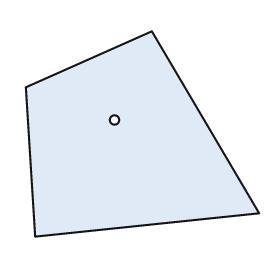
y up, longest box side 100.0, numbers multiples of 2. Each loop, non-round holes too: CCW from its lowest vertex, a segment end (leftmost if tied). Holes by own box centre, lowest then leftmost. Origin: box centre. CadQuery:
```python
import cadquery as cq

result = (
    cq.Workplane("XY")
    .moveTo(-46.0, -44.0)
    .lineTo(50.0, -34.0)
    .lineTo(4.0, 44.0)
    .lineTo(-50.0, 20.0)
    .close()
    .moveTo(-12.0, 6.0)
    .circle(2.0)
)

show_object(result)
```